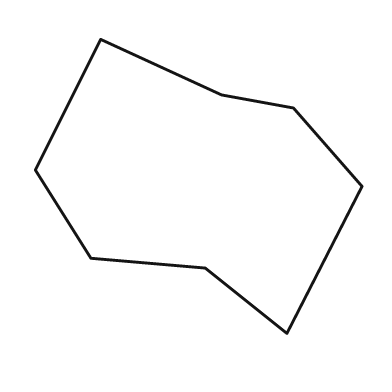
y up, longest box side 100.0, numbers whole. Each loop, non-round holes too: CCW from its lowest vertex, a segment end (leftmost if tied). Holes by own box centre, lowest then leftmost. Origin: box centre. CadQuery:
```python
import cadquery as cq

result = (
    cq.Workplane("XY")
    .moveTo(27.0, -45.0)
    .lineTo(50.0, 0.0)
    .lineTo(29.0, 24.0)
    .lineTo(7.0, 28.0)
    .lineTo(-30.0, 45.0)
    .lineTo(-50.0, 5.0)
    .lineTo(-33.0, -22.0)
    .lineTo(2.0, -25.0)
    .close()
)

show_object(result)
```